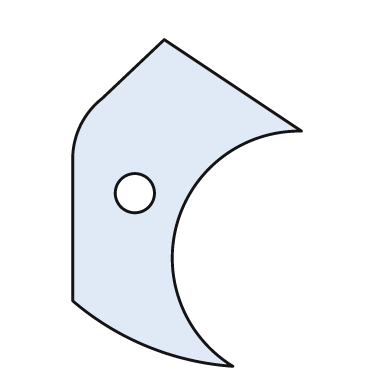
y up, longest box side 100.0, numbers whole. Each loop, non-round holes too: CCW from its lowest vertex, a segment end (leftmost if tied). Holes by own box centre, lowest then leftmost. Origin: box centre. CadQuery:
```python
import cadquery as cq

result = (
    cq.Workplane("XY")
    .moveTo(14.0, -50.0)
    .threePointArc((-3.0, -6.0), (35.0, 22.0))
    .lineTo(-7.0, 50.0)
    .lineTo(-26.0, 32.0)
    .threePointArc((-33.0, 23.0), (-35.0, 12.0))
    .lineTo(-35.0, -30.0)
    .threePointArc((-12.0, -44.0), (14.0, -50.0))
    .close()
    .moveTo(-16.0, 3.0)
    .circle(6.0)
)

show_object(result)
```